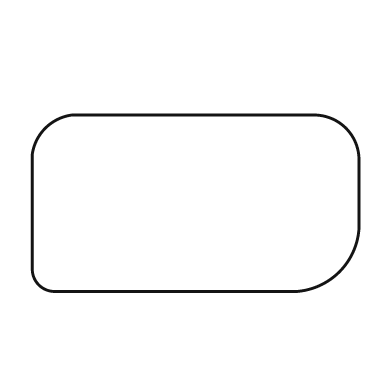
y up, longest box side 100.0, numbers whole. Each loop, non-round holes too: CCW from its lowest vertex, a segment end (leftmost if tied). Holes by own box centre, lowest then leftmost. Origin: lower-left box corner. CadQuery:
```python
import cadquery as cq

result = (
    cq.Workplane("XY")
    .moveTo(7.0, 0.0)
    .lineTo(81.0, 0.0)
    .threePointArc((94.0, 6.0), (100.0, 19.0))
    .lineTo(100.0, 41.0)
    .threePointArc((96.0, 50.0), (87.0, 54.0))
    .lineTo(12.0, 54.0)
    .threePointArc((4.0, 50.0), (0.0, 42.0))
    .lineTo(0.0, 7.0)
    .threePointArc((2.0, 2.0), (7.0, 0.0))
    .close()
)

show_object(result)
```